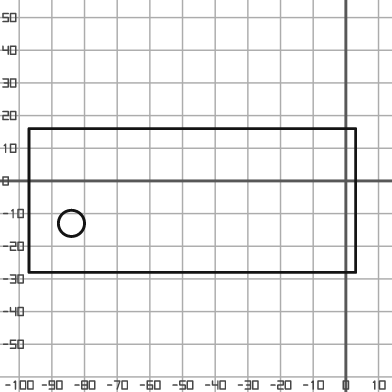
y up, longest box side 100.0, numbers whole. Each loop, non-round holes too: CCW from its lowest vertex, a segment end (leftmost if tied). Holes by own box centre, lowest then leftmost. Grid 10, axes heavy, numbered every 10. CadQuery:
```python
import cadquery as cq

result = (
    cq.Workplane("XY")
    .moveTo(-97.0, -28.0)
    .lineTo(3.0, -28.0)
    .lineTo(3.0, 16.0)
    .lineTo(-97.0, 16.0)
    .close()
    .moveTo(-84.0, -13.0)
    .circle(4.0)
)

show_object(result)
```